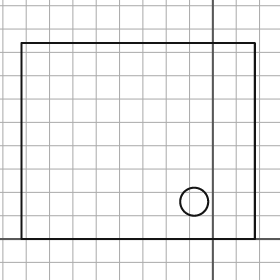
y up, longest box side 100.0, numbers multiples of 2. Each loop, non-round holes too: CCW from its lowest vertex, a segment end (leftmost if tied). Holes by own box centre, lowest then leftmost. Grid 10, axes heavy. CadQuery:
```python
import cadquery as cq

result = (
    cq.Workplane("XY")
    .moveTo(-82.0, 0.0)
    .lineTo(18.0, 0.0)
    .lineTo(18.0, 84.0)
    .lineTo(-82.0, 84.0)
    .close()
    .moveTo(-8.0, 16.0)
    .circle(6.0)
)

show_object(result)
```